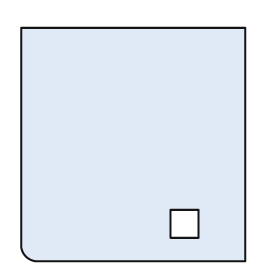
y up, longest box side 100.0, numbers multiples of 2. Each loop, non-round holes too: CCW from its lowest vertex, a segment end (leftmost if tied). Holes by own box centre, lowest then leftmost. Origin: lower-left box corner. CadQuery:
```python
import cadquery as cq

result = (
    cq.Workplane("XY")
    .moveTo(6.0, 0.0)
    .lineTo(96.0, 0.0)
    .lineTo(96.0, 100.0)
    .lineTo(0.0, 100.0)
    .lineTo(0.0, 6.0)
    .threePointArc((2.0, 2.0), (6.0, 0.0))
    .close()
    .moveTo(64.0, 10.0)
    .lineTo(76.0, 10.0)
    .lineTo(76.0, 22.0)
    .lineTo(64.0, 22.0)
    .close()
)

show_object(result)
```